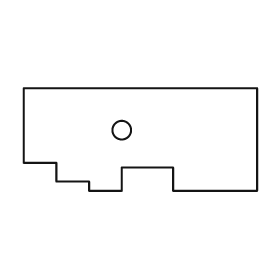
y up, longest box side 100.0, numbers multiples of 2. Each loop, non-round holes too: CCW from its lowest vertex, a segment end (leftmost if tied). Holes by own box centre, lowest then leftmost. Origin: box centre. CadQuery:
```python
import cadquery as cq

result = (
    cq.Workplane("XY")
    .moveTo(-22.0, -22.0)
    .lineTo(-8.0, -22.0)
    .lineTo(-8.0, -12.0)
    .lineTo(14.0, -12.0)
    .lineTo(14.0, -22.0)
    .lineTo(50.0, -22.0)
    .lineTo(50.0, 22.0)
    .lineTo(-50.0, 22.0)
    .lineTo(-50.0, -10.0)
    .lineTo(-36.0, -10.0)
    .lineTo(-36.0, -18.0)
    .lineTo(-22.0, -18.0)
    .close()
    .moveTo(-8.0, 4.0)
    .circle(4.0)
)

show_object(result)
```